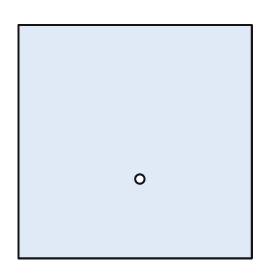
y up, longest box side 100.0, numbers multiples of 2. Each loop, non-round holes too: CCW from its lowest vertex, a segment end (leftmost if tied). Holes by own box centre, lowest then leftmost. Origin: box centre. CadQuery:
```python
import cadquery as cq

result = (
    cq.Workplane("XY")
    .moveTo(-50.0, -50.0)
    .lineTo(50.0, -50.0)
    .lineTo(50.0, 50.0)
    .lineTo(-50.0, 50.0)
    .close()
    .moveTo(2.0, -16.0)
    .circle(2.0)
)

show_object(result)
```